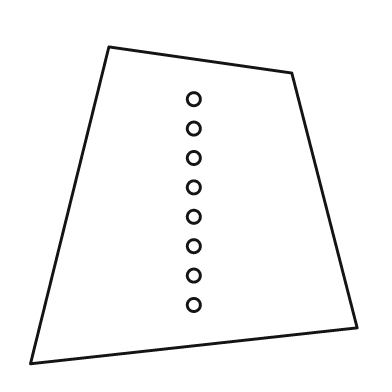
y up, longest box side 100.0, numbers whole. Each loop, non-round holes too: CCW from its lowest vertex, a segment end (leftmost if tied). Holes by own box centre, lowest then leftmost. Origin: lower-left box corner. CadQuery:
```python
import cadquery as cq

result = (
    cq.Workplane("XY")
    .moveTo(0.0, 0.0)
    .lineTo(100.0, 11.0)
    .lineTo(80.0, 89.0)
    .lineTo(24.0, 97.0)
    .close()
    .moveTo(50.0, 18.0)
    .circle(2.0)
    .moveTo(50.0, 27.0)
    .circle(2.0)
    .moveTo(50.0, 36.0)
    .circle(2.0)
    .moveTo(50.0, 45.0)
    .circle(2.0)
    .moveTo(50.0, 54.0)
    .circle(2.0)
    .moveTo(50.0, 63.0)
    .circle(2.0)
    .moveTo(50.0, 72.0)
    .circle(2.0)
    .moveTo(50.0, 81.0)
    .circle(2.0)
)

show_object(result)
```